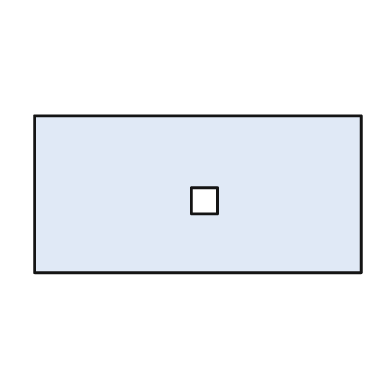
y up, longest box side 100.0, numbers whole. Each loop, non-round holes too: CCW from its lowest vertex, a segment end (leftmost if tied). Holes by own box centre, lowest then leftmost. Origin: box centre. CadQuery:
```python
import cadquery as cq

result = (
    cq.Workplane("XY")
    .moveTo(-50.0, -24.0)
    .lineTo(50.0, -24.0)
    .lineTo(50.0, 24.0)
    .lineTo(-50.0, 24.0)
    .close()
    .moveTo(-2.0, -6.0)
    .lineTo(6.0, -6.0)
    .lineTo(6.0, 2.0)
    .lineTo(-2.0, 2.0)
    .close()
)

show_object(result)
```